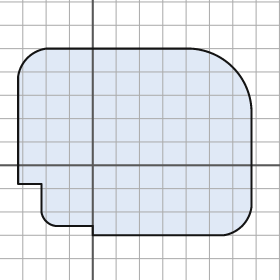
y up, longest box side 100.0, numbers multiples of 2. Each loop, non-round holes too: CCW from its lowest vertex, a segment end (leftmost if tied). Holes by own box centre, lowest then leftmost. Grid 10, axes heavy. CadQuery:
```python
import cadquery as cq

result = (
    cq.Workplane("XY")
    .moveTo(0.0, -30.0)
    .lineTo(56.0, -30.0)
    .threePointArc((64.0, -26.0), (68.0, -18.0))
    .lineTo(68.0, 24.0)
    .threePointArc((60.0, 42.0), (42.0, 50.0))
    .lineTo(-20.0, 50.0)
    .threePointArc((-28.0, 46.0), (-32.0, 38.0))
    .lineTo(-32.0, -8.0)
    .lineTo(-22.0, -8.0)
    .lineTo(-22.0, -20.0)
    .threePointArc((-20.0, -24.0), (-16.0, -26.0))
    .lineTo(0.0, -26.0)
    .close()
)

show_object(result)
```